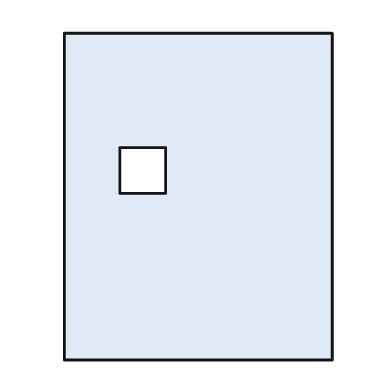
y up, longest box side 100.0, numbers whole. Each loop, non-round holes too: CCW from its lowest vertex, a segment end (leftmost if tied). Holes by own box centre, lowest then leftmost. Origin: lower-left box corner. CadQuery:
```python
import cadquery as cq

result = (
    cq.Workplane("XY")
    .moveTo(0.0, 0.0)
    .lineTo(82.0, 0.0)
    .lineTo(82.0, 100.0)
    .lineTo(0.0, 100.0)
    .close()
    .moveTo(17.0, 51.0)
    .lineTo(31.0, 51.0)
    .lineTo(31.0, 65.0)
    .lineTo(17.0, 65.0)
    .close()
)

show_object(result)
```